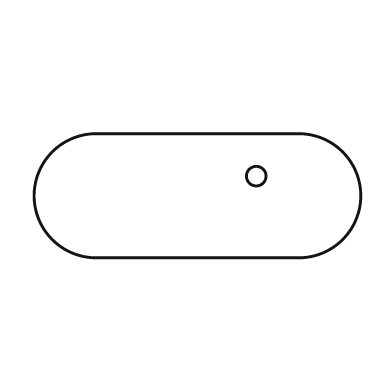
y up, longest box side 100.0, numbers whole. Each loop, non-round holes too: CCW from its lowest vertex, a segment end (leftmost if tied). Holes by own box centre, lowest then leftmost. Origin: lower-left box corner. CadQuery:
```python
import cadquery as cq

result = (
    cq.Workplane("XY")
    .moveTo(19.0, 0.0)
    .lineTo(81.0, 0.0)
    .threePointArc((100.0, 19.0), (81.0, 38.0))
    .lineTo(19.0, 38.0)
    .threePointArc((0.0, 19.0), (19.0, 0.0))
    .close()
    .moveTo(68.0, 25.0)
    .circle(3.0)
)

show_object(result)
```